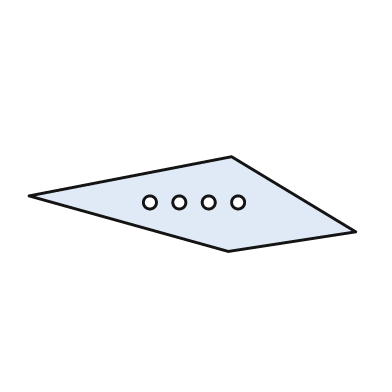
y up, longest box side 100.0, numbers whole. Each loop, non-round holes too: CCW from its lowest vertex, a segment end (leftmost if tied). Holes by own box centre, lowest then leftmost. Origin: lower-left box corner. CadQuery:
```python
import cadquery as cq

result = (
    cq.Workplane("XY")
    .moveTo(61.0, 0.0)
    .lineTo(100.0, 6.0)
    .lineTo(62.0, 29.0)
    .lineTo(0.0, 17.0)
    .close()
    .moveTo(37.0, 15.0)
    .circle(2.0)
    .moveTo(46.0, 15.0)
    .circle(2.0)
    .moveTo(55.0, 15.0)
    .circle(2.0)
    .moveTo(64.0, 15.0)
    .circle(2.0)
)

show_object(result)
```